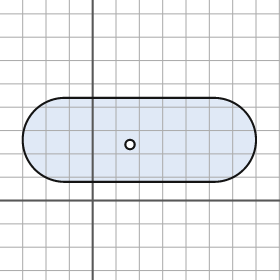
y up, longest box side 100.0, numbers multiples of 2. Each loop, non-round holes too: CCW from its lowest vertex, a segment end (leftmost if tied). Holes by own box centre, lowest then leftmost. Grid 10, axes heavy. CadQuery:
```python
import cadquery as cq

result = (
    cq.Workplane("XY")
    .moveTo(-12.0, 8.0)
    .lineTo(52.0, 8.0)
    .threePointArc((70.0, 26.0), (52.0, 44.0))
    .lineTo(-12.0, 44.0)
    .threePointArc((-30.0, 26.0), (-12.0, 8.0))
    .close()
    .moveTo(16.0, 24.0)
    .circle(2.0)
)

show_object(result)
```